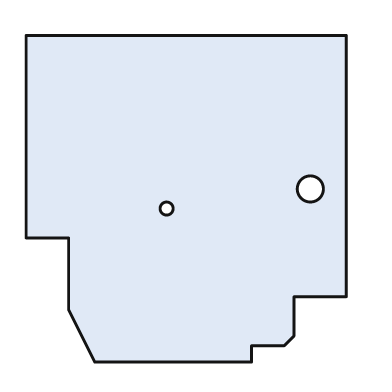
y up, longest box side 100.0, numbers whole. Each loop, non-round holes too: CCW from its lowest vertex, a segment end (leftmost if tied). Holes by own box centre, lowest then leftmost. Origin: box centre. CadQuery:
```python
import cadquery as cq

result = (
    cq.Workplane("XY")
    .moveTo(-28.0, -50.0)
    .lineTo(20.0, -50.0)
    .lineTo(20.0, -45.0)
    .lineTo(30.0, -45.0)
    .lineTo(33.0, -42.0)
    .lineTo(33.0, -30.0)
    .lineTo(49.0, -30.0)
    .lineTo(49.0, 50.0)
    .lineTo(-49.0, 50.0)
    .lineTo(-49.0, -12.0)
    .lineTo(-36.0, -12.0)
    .lineTo(-36.0, -34.0)
    .close()
    .moveTo(-6.0, -3.0)
    .circle(2.0)
    .moveTo(38.0, 3.0)
    .circle(4.0)
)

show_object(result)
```